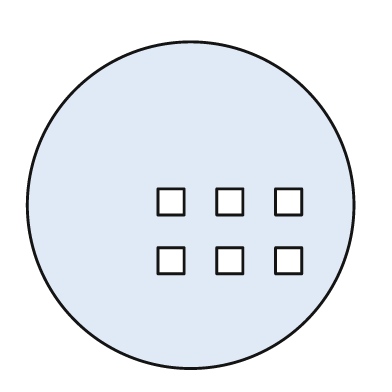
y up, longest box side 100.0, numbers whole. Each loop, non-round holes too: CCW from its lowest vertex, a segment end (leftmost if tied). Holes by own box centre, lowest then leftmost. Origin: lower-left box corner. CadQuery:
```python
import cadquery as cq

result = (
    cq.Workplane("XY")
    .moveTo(50.0, 50.0)
    .circle(50.0)
    .moveTo(40.0, 29.0)
    .lineTo(48.0, 29.0)
    .lineTo(48.0, 37.0)
    .lineTo(40.0, 37.0)
    .close()
    .moveTo(58.0, 29.0)
    .lineTo(66.0, 29.0)
    .lineTo(66.0, 37.0)
    .lineTo(58.0, 37.0)
    .close()
    .moveTo(76.0, 29.0)
    .lineTo(84.0, 29.0)
    .lineTo(84.0, 37.0)
    .lineTo(76.0, 37.0)
    .close()
    .moveTo(40.0, 47.0)
    .lineTo(48.0, 47.0)
    .lineTo(48.0, 55.0)
    .lineTo(40.0, 55.0)
    .close()
    .moveTo(58.0, 47.0)
    .lineTo(66.0, 47.0)
    .lineTo(66.0, 55.0)
    .lineTo(58.0, 55.0)
    .close()
    .moveTo(76.0, 47.0)
    .lineTo(84.0, 47.0)
    .lineTo(84.0, 55.0)
    .lineTo(76.0, 55.0)
    .close()
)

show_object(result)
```